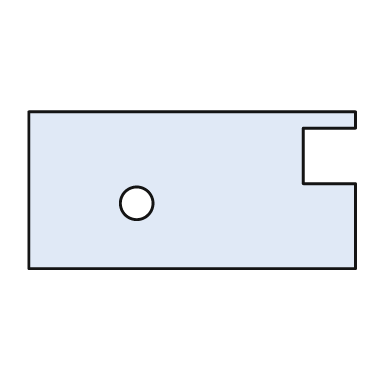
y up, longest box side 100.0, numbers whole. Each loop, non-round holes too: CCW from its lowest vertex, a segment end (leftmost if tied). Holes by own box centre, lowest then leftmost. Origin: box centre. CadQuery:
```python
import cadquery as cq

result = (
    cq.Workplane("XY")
    .moveTo(-50.0, -24.0)
    .lineTo(50.0, -24.0)
    .lineTo(50.0, 2.0)
    .lineTo(34.0, 2.0)
    .lineTo(34.0, 19.0)
    .lineTo(50.0, 19.0)
    .lineTo(50.0, 24.0)
    .lineTo(-50.0, 24.0)
    .close()
    .moveTo(-17.0, -4.0)
    .circle(5.0)
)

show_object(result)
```